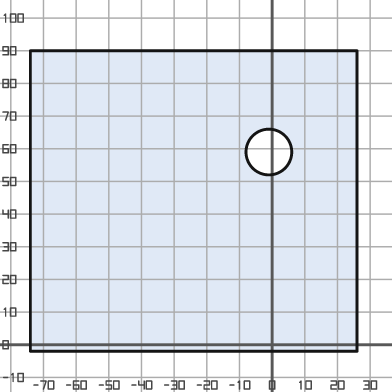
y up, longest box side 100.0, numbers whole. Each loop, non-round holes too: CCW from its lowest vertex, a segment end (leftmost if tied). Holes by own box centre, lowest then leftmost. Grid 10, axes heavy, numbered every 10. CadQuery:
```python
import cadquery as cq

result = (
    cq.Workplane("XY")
    .moveTo(-74.0, -2.0)
    .lineTo(26.0, -2.0)
    .lineTo(26.0, 90.0)
    .lineTo(-74.0, 90.0)
    .close()
    .moveTo(-1.0, 59.0)
    .circle(7.0)
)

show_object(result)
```